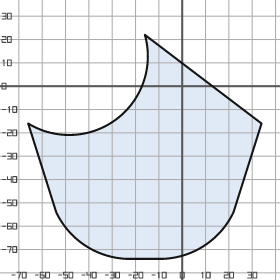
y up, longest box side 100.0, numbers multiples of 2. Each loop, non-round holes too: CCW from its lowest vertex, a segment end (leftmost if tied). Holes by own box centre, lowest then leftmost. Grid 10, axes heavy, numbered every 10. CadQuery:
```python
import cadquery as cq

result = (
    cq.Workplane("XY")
    .moveTo(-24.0, -74.0)
    .lineTo(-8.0, -74.0)
    .threePointArc((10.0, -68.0), (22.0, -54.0))
    .lineTo(34.0, -16.0)
    .lineTo(-16.0, 22.0)
    .threePointArc((-28.0, -14.0), (-66.0, -16.0))
    .lineTo(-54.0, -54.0)
    .threePointArc((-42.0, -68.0), (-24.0, -74.0))
    .close()
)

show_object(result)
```